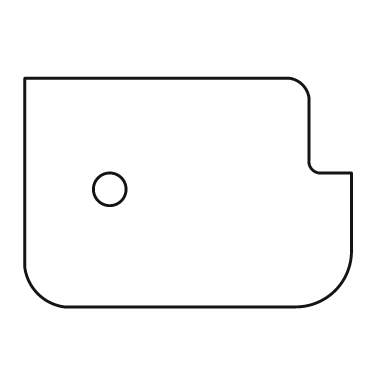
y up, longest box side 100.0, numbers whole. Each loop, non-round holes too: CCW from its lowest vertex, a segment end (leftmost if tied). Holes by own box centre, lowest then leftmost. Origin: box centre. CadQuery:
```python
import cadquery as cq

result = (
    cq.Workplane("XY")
    .moveTo(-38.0, -35.0)
    .lineTo(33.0, -35.0)
    .threePointArc((45.0, -30.0), (50.0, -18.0))
    .lineTo(50.0, 6.0)
    .lineTo(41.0, 6.0)
    .threePointArc((38.0, 7.0), (37.0, 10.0))
    .lineTo(37.0, 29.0)
    .threePointArc((35.0, 33.0), (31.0, 35.0))
    .lineTo(-50.0, 35.0)
    .lineTo(-50.0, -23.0)
    .threePointArc((-46.0, -31.0), (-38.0, -35.0))
    .close()
    .moveTo(-24.0, 1.0)
    .circle(5.0)
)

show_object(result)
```